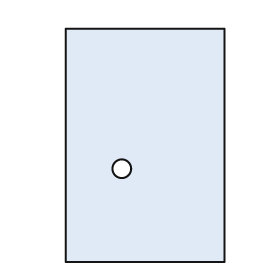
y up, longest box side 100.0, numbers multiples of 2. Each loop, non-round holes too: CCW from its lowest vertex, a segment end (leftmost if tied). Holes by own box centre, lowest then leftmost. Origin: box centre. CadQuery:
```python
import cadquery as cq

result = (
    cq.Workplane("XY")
    .moveTo(-34.0, -50.0)
    .lineTo(34.0, -50.0)
    .lineTo(34.0, 50.0)
    .lineTo(-34.0, 50.0)
    .close()
    .moveTo(-10.0, -10.0)
    .circle(4.0)
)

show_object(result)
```